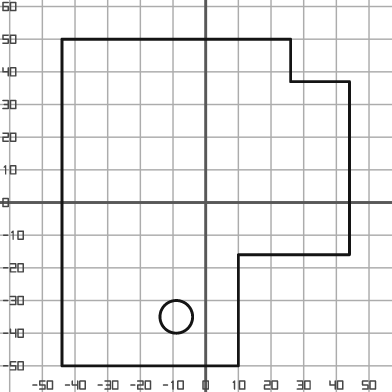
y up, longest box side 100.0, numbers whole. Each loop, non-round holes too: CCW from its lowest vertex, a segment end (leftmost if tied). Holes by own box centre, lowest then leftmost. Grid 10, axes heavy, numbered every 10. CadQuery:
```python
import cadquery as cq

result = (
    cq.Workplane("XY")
    .moveTo(-44.0, -50.0)
    .lineTo(10.0, -50.0)
    .lineTo(10.0, -16.0)
    .lineTo(44.0, -16.0)
    .lineTo(44.0, 37.0)
    .lineTo(26.0, 37.0)
    .lineTo(26.0, 50.0)
    .lineTo(-44.0, 50.0)
    .close()
    .moveTo(-9.0, -35.0)
    .circle(5.0)
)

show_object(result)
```